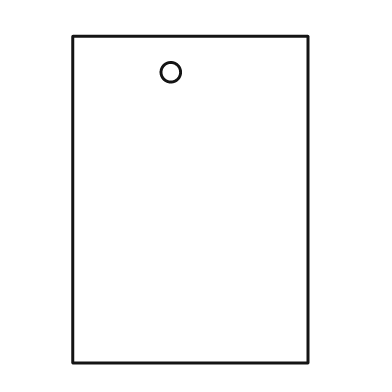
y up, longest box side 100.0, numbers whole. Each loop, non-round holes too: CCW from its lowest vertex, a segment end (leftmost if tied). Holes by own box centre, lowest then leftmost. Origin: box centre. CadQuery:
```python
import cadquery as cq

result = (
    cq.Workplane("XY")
    .moveTo(-36.0, -50.0)
    .lineTo(36.0, -50.0)
    .lineTo(36.0, 50.0)
    .lineTo(-36.0, 50.0)
    .close()
    .moveTo(-6.0, 39.0)
    .circle(3.0)
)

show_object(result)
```